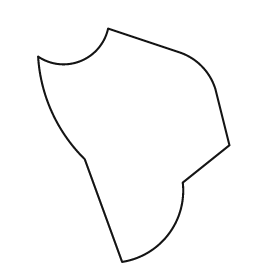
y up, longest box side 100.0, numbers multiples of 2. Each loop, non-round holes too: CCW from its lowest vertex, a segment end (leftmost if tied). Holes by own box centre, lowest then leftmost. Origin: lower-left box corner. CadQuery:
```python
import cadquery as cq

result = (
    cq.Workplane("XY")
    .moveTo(36.0, 0.0)
    .threePointArc((56.0, 12.0), (62.0, 34.0))
    .lineTo(82.0, 50.0)
    .lineTo(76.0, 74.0)
    .threePointArc((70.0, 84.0), (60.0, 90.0))
    .lineTo(30.0, 100.0)
    .threePointArc((18.0, 86.0), (0.0, 88.0))
    .threePointArc((6.0, 64.0), (20.0, 44.0))
    .close()
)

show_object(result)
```